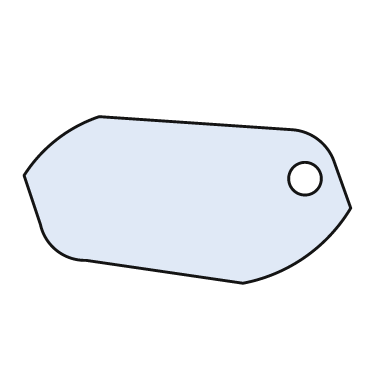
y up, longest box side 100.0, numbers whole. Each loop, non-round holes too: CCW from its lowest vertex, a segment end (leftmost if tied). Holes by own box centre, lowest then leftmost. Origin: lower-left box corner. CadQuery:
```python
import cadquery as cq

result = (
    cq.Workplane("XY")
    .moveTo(67.0, 0.0)
    .threePointArc((86.0, 8.0), (100.0, 23.0))
    .lineTo(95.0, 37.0)
    .threePointArc((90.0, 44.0), (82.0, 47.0))
    .lineTo(23.0, 51.0)
    .threePointArc((10.0, 44.0), (0.0, 33.0))
    .lineTo(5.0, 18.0)
    .threePointArc((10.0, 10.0), (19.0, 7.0))
    .close()
    .moveTo(86.0, 32.0)
    .circle(5.0)
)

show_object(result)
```